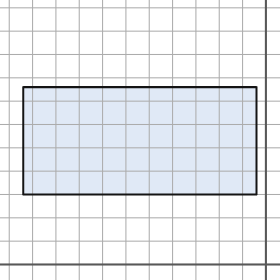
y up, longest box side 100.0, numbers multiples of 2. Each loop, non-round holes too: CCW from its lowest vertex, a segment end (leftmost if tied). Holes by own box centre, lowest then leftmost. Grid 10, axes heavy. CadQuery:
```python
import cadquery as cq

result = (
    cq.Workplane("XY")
    .moveTo(-104.0, 30.0)
    .lineTo(-4.0, 30.0)
    .lineTo(-4.0, 76.0)
    .lineTo(-104.0, 76.0)
    .close()
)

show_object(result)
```